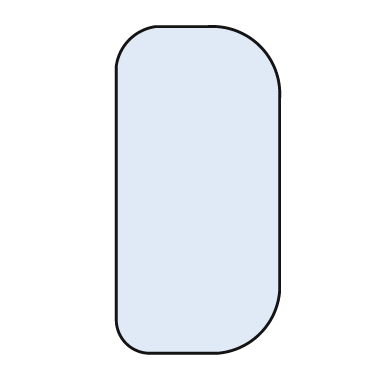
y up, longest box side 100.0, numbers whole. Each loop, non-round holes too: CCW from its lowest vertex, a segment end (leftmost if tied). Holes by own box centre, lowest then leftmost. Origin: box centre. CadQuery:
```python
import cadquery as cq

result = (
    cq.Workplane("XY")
    .moveTo(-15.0, -50.0)
    .lineTo(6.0, -50.0)
    .threePointArc((19.0, -44.0), (25.0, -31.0))
    .lineTo(25.0, 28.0)
    .threePointArc((19.0, 44.0), (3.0, 50.0))
    .lineTo(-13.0, 50.0)
    .threePointArc((-21.0, 46.0), (-25.0, 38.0))
    .lineTo(-25.0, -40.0)
    .threePointArc((-22.0, -47.0), (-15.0, -50.0))
    .close()
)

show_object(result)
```